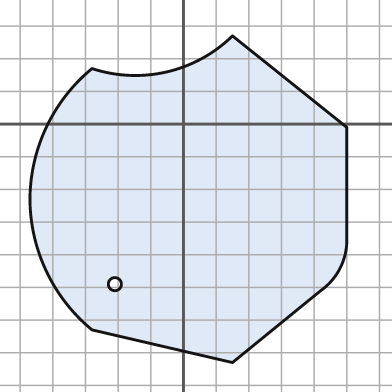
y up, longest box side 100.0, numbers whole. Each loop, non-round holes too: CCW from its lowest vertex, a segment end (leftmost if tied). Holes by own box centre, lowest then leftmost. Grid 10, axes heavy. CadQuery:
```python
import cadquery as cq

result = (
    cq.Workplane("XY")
    .moveTo(15.0, -73.0)
    .lineTo(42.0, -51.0)
    .threePointArc((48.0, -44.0), (50.0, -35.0))
    .lineTo(50.0, -1.0)
    .lineTo(15.0, 27.0)
    .threePointArc((-5.0, 16.0), (-28.0, 17.0))
    .threePointArc((-42.0, -1.0), (-47.0, -23.0))
    .threePointArc((-42.0, -45.0), (-28.0, -63.0))
    .close()
    .moveTo(-21.0, -49.0)
    .circle(2.0)
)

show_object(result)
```